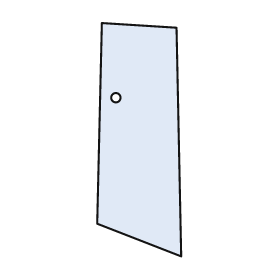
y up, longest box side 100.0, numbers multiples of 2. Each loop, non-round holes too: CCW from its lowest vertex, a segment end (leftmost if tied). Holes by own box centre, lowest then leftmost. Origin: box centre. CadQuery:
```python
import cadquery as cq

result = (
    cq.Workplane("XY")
    .moveTo(18.0, -50.0)
    .lineTo(16.0, 48.0)
    .lineTo(-16.0, 50.0)
    .lineTo(-18.0, -36.0)
    .close()
    .moveTo(-10.0, 18.0)
    .circle(2.0)
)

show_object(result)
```